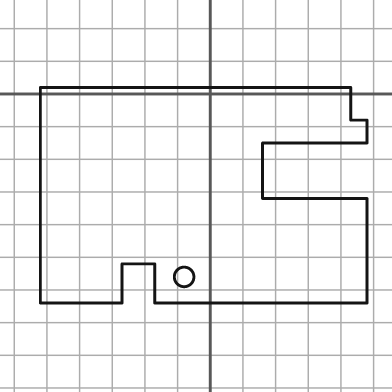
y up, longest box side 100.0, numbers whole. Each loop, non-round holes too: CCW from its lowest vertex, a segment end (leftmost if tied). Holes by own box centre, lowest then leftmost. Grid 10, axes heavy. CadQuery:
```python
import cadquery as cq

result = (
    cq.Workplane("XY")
    .moveTo(-52.0, -64.0)
    .lineTo(-27.0, -64.0)
    .lineTo(-27.0, -52.0)
    .lineTo(-17.0, -52.0)
    .lineTo(-17.0, -64.0)
    .lineTo(48.0, -64.0)
    .lineTo(48.0, -32.0)
    .lineTo(16.0, -32.0)
    .lineTo(16.0, -15.0)
    .lineTo(48.0, -15.0)
    .lineTo(48.0, -8.0)
    .lineTo(43.0, -8.0)
    .lineTo(43.0, 2.0)
    .lineTo(-52.0, 2.0)
    .close()
    .moveTo(-8.0, -56.0)
    .circle(3.0)
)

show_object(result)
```